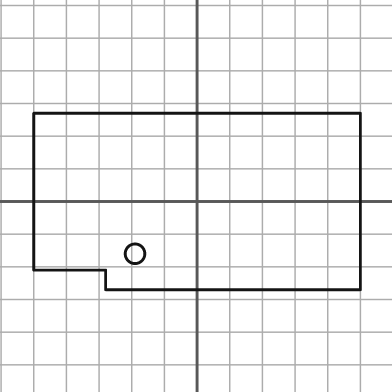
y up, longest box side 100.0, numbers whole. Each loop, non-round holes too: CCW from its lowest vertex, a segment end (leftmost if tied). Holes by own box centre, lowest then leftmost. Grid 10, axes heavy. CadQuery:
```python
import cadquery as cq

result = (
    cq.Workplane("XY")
    .moveTo(-28.0, -27.0)
    .lineTo(50.0, -27.0)
    .lineTo(50.0, 27.0)
    .lineTo(-50.0, 27.0)
    .lineTo(-50.0, -21.0)
    .lineTo(-28.0, -21.0)
    .close()
    .moveTo(-19.0, -16.0)
    .circle(3.0)
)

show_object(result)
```